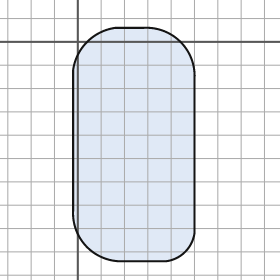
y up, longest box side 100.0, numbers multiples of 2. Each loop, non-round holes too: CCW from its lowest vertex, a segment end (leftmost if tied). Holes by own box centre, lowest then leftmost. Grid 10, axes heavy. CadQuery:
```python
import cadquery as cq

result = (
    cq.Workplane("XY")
    .moveTo(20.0, -94.0)
    .lineTo(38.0, -94.0)
    .threePointArc((46.0, -90.0), (50.0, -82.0))
    .lineTo(50.0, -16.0)
    .threePointArc((44.0, 0.0), (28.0, 6.0))
    .lineTo(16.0, 6.0)
    .threePointArc((4.0, 0.0), (-2.0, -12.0))
    .lineTo(-2.0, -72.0)
    .threePointArc((4.0, -88.0), (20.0, -94.0))
    .close()
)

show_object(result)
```